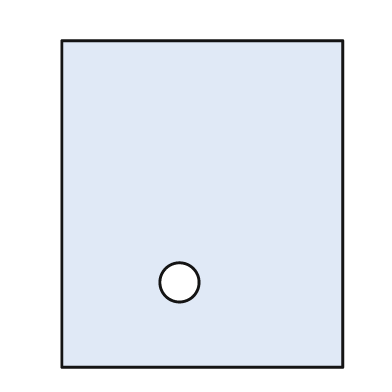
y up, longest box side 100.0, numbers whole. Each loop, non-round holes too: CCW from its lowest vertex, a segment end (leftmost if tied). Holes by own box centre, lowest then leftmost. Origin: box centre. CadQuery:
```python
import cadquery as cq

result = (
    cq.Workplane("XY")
    .moveTo(-43.0, -50.0)
    .lineTo(43.0, -50.0)
    .lineTo(43.0, 50.0)
    .lineTo(-43.0, 50.0)
    .close()
    .moveTo(-7.0, -24.0)
    .circle(6.0)
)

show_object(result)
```